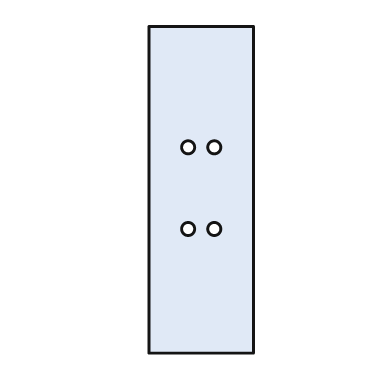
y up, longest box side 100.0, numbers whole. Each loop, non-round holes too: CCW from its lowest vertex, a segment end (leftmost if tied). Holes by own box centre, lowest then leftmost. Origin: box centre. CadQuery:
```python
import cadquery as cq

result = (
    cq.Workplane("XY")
    .moveTo(-16.0, -50.0)
    .lineTo(16.0, -50.0)
    .lineTo(16.0, 50.0)
    .lineTo(-16.0, 50.0)
    .close()
    .moveTo(-4.0, -12.0)
    .circle(2.0)
    .moveTo(4.0, -12.0)
    .circle(2.0)
    .moveTo(-4.0, 13.0)
    .circle(2.0)
    .moveTo(4.0, 13.0)
    .circle(2.0)
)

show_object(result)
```